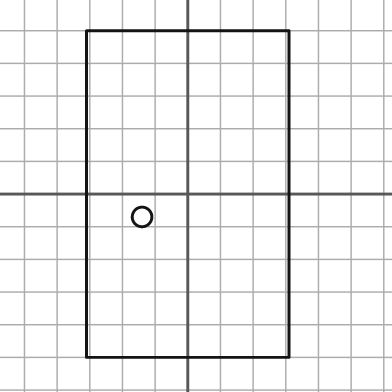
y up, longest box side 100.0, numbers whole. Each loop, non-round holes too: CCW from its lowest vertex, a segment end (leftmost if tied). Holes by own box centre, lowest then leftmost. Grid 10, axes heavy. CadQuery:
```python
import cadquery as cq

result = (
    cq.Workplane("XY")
    .moveTo(-31.0, -50.0)
    .lineTo(31.0, -50.0)
    .lineTo(31.0, 50.0)
    .lineTo(-31.0, 50.0)
    .close()
    .moveTo(-14.0, -7.0)
    .circle(3.0)
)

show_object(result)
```